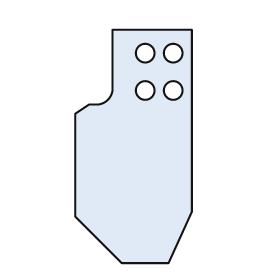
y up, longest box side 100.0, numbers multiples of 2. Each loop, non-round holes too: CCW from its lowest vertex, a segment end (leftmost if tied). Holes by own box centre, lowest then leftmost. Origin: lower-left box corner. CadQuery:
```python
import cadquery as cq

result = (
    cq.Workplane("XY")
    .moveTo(20.0, 0.0)
    .lineTo(40.0, 0.0)
    .lineTo(50.0, 22.0)
    .lineTo(50.0, 100.0)
    .lineTo(16.0, 100.0)
    .lineTo(16.0, 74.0)
    .threePointArc((14.0, 70.0), (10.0, 68.0))
    .lineTo(6.0, 68.0)
    .lineTo(0.0, 64.0)
    .lineTo(0.0, 20.0)
    .close()
    .moveTo(30.0, 74.0)
    .circle(4.0)
    .moveTo(42.0, 74.0)
    .circle(4.0)
    .moveTo(30.0, 90.0)
    .circle(4.0)
    .moveTo(42.0, 90.0)
    .circle(4.0)
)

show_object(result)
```